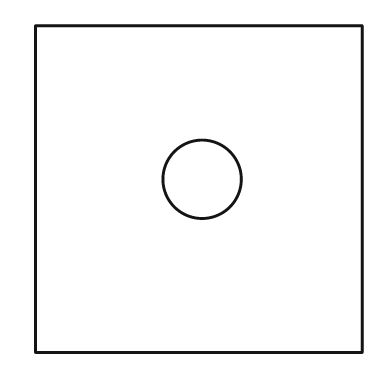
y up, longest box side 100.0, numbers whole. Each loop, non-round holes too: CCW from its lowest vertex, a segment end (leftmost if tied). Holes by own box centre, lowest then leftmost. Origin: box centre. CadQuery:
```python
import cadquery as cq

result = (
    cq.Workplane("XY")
    .moveTo(-50.0, -50.0)
    .lineTo(50.0, -50.0)
    .lineTo(50.0, 50.0)
    .lineTo(-50.0, 50.0)
    .close()
    .moveTo(1.0, 3.0)
    .circle(12.0)
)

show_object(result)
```